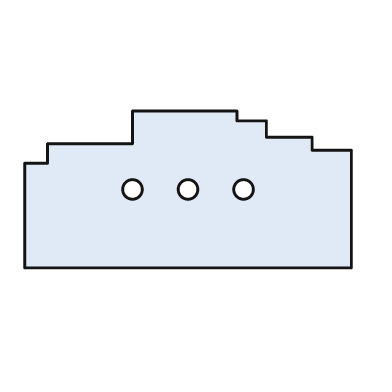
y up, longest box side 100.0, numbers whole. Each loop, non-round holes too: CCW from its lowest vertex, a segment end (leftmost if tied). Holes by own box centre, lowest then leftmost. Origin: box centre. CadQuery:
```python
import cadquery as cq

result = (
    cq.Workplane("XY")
    .moveTo(-50.0, -24.0)
    .lineTo(50.0, -24.0)
    .lineTo(50.0, 12.0)
    .lineTo(38.0, 12.0)
    .lineTo(38.0, 16.0)
    .lineTo(24.0, 16.0)
    .lineTo(24.0, 21.0)
    .lineTo(15.0, 21.0)
    .lineTo(15.0, 24.0)
    .lineTo(-17.0, 24.0)
    .lineTo(-17.0, 14.0)
    .lineTo(-43.0, 14.0)
    .lineTo(-43.0, 8.0)
    .lineTo(-50.0, 8.0)
    .close()
    .moveTo(-17.0, 0.0)
    .circle(3.0)
    .moveTo(0.0, 0.0)
    .circle(3.0)
    .moveTo(17.0, 0.0)
    .circle(3.0)
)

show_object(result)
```